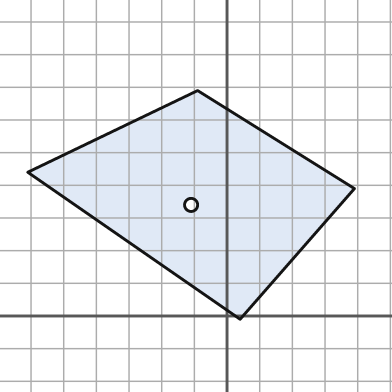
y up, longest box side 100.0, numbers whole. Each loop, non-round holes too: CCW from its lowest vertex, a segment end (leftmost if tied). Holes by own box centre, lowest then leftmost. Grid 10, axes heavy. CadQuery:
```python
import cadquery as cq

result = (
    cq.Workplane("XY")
    .moveTo(4.0, -1.0)
    .lineTo(39.0, 39.0)
    .lineTo(-9.0, 69.0)
    .lineTo(-61.0, 44.0)
    .close()
    .moveTo(-11.0, 34.0)
    .circle(2.0)
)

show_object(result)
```